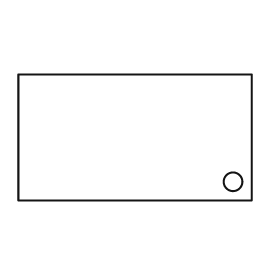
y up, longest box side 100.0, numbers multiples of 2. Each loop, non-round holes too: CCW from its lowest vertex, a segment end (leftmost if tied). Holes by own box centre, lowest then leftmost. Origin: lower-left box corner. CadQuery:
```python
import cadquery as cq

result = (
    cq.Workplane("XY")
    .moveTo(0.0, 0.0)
    .lineTo(100.0, 0.0)
    .lineTo(100.0, 54.0)
    .lineTo(0.0, 54.0)
    .close()
    .moveTo(92.0, 8.0)
    .circle(4.0)
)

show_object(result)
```